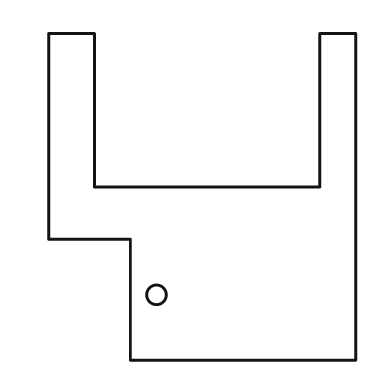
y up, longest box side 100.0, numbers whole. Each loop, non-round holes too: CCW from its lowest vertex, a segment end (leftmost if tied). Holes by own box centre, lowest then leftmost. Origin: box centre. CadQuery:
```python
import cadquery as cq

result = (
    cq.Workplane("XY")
    .moveTo(-22.0, -50.0)
    .lineTo(47.0, -50.0)
    .lineTo(47.0, 50.0)
    .lineTo(36.0, 50.0)
    .lineTo(36.0, 3.0)
    .lineTo(-33.0, 3.0)
    .lineTo(-33.0, 50.0)
    .lineTo(-47.0, 50.0)
    .lineTo(-47.0, -13.0)
    .lineTo(-22.0, -13.0)
    .close()
    .moveTo(-14.0, -30.0)
    .circle(3.0)
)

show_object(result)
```